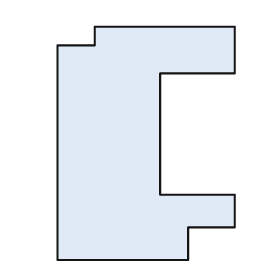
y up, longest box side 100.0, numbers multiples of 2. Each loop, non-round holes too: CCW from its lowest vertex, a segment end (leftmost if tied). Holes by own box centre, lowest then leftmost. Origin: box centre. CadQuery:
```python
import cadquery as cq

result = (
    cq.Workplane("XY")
    .moveTo(-38.0, -50.0)
    .lineTo(18.0, -50.0)
    .lineTo(18.0, -36.0)
    .lineTo(38.0, -36.0)
    .lineTo(38.0, -22.0)
    .lineTo(6.0, -22.0)
    .lineTo(6.0, 30.0)
    .lineTo(38.0, 30.0)
    .lineTo(38.0, 50.0)
    .lineTo(-22.0, 50.0)
    .lineTo(-22.0, 42.0)
    .lineTo(-38.0, 42.0)
    .close()
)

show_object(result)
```